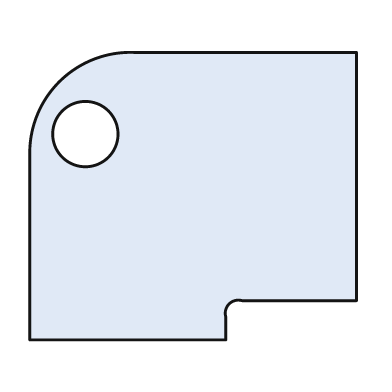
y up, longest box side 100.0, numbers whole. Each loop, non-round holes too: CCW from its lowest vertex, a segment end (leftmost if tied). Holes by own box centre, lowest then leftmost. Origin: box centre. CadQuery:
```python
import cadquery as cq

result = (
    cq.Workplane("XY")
    .moveTo(-50.0, -44.0)
    .lineTo(10.0, -44.0)
    .lineTo(10.0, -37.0)
    .threePointArc((11.0, -33.0), (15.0, -32.0))
    .lineTo(50.0, -32.0)
    .lineTo(50.0, 44.0)
    .lineTo(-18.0, 44.0)
    .threePointArc((-41.0, 35.0), (-50.0, 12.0))
    .close()
    .moveTo(-33.0, 19.0)
    .circle(10.0)
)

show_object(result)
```